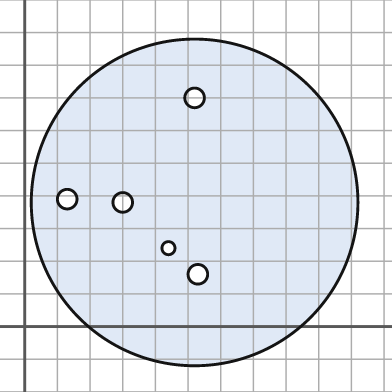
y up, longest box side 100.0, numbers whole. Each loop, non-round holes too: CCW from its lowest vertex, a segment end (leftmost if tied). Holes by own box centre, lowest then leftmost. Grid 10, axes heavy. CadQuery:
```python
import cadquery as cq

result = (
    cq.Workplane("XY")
    .moveTo(52.0, 38.0)
    .circle(50.0)
    .moveTo(53.0, 16.0)
    .circle(3.0)
    .moveTo(44.0, 24.0)
    .circle(2.0)
    .moveTo(30.0, 38.0)
    .circle(3.0)
    .moveTo(13.0, 39.0)
    .circle(3.0)
    .moveTo(52.0, 70.0)
    .circle(3.0)
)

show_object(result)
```